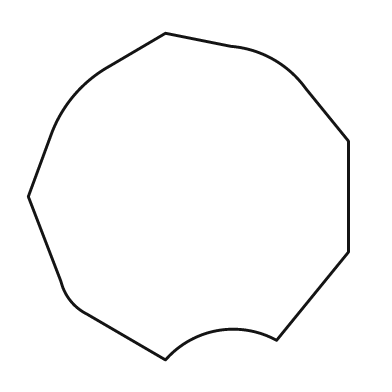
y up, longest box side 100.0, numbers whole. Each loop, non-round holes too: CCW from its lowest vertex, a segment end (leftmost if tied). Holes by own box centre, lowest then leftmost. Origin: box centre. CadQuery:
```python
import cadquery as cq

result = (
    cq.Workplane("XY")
    .moveTo(-7.0, -50.0)
    .threePointArc((9.0, -41.0), (27.0, -44.0))
    .lineTo(49.0, -17.0)
    .lineTo(49.0, 17.0)
    .lineTo(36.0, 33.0)
    .threePointArc((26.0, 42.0), (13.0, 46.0))
    .lineTo(-7.0, 50.0)
    .lineTo(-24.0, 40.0)
    .threePointArc((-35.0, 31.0), (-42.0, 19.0))
    .lineTo(-49.0, 0.0)
    .lineTo(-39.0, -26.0)
    .threePointArc((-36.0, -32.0), (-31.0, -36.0))
    .close()
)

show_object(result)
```